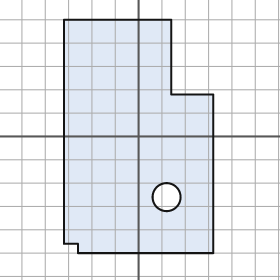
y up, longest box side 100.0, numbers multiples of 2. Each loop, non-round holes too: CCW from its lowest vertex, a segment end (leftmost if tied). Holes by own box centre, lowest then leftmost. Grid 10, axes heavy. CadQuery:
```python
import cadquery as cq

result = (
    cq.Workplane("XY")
    .moveTo(-26.0, -50.0)
    .lineTo(32.0, -50.0)
    .lineTo(32.0, 18.0)
    .lineTo(14.0, 18.0)
    .lineTo(14.0, 50.0)
    .lineTo(-32.0, 50.0)
    .lineTo(-32.0, -46.0)
    .lineTo(-26.0, -46.0)
    .close()
    .moveTo(12.0, -26.0)
    .circle(6.0)
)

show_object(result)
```